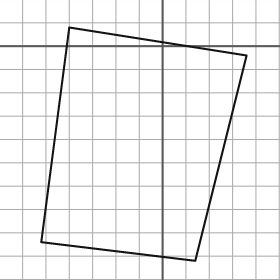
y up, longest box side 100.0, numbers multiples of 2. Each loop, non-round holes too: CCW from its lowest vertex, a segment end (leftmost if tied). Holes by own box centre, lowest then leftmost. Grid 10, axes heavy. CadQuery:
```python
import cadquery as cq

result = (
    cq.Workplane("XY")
    .moveTo(14.0, -92.0)
    .lineTo(36.0, -4.0)
    .lineTo(-40.0, 8.0)
    .lineTo(-52.0, -84.0)
    .close()
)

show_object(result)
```